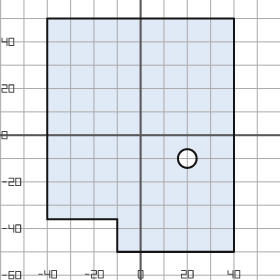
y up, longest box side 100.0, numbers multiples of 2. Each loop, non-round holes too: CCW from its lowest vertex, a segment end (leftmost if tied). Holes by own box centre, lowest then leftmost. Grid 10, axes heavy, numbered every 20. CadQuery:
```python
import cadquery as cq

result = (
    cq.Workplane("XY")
    .moveTo(-10.0, -50.0)
    .lineTo(40.0, -50.0)
    .lineTo(40.0, 50.0)
    .lineTo(-40.0, 50.0)
    .lineTo(-40.0, -36.0)
    .lineTo(-10.0, -36.0)
    .close()
    .moveTo(20.0, -10.0)
    .circle(4.0)
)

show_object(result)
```